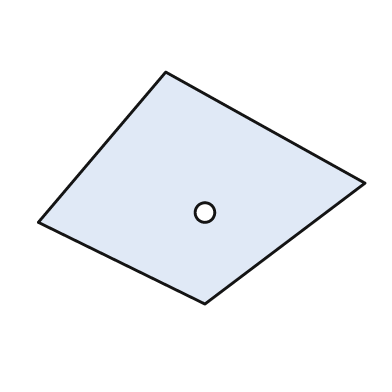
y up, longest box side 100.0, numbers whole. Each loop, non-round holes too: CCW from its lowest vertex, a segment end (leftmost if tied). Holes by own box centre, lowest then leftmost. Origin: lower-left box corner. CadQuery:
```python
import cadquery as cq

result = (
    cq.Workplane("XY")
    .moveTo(51.0, 0.0)
    .lineTo(100.0, 37.0)
    .lineTo(39.0, 71.0)
    .lineTo(0.0, 25.0)
    .close()
    .moveTo(51.0, 28.0)
    .circle(3.0)
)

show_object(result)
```